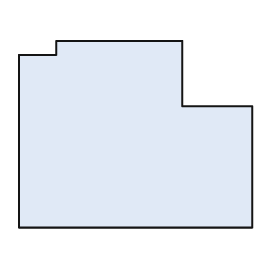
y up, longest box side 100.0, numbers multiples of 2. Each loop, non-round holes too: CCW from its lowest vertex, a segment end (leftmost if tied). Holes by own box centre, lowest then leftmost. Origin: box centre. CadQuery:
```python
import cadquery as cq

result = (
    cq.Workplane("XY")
    .moveTo(-50.0, -40.0)
    .lineTo(50.0, -40.0)
    .lineTo(50.0, 12.0)
    .lineTo(20.0, 12.0)
    .lineTo(20.0, 40.0)
    .lineTo(-34.0, 40.0)
    .lineTo(-34.0, 34.0)
    .lineTo(-50.0, 34.0)
    .close()
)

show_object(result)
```